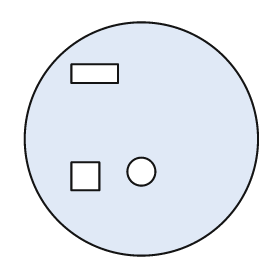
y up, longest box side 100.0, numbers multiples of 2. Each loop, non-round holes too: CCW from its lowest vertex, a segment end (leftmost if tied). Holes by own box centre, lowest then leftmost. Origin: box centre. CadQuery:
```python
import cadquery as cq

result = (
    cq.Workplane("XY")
    .moveTo(0.0, 0.0)
    .circle(50.0)
    .moveTo(-30.0, -22.0)
    .lineTo(-18.0, -22.0)
    .lineTo(-18.0, -10.0)
    .lineTo(-30.0, -10.0)
    .close()
    .moveTo(0.0, -14.0)
    .circle(6.0)
    .moveTo(-30.0, 24.0)
    .lineTo(-10.0, 24.0)
    .lineTo(-10.0, 32.0)
    .lineTo(-30.0, 32.0)
    .close()
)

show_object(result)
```